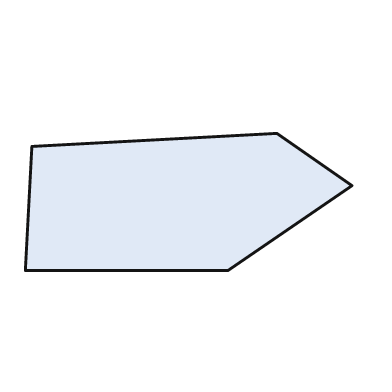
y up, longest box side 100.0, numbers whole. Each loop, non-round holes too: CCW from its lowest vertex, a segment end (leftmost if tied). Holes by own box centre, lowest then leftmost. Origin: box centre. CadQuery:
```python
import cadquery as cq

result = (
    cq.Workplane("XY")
    .moveTo(-50.0, -21.0)
    .lineTo(12.0, -21.0)
    .lineTo(50.0, 5.0)
    .lineTo(27.0, 21.0)
    .lineTo(-48.0, 17.0)
    .close()
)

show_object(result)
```